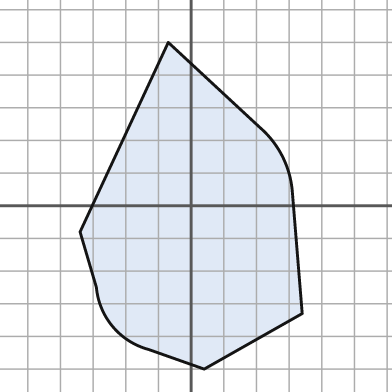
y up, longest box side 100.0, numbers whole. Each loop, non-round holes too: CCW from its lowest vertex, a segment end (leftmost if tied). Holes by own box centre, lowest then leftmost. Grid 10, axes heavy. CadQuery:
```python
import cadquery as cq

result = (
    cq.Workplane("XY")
    .moveTo(4.0, -50.0)
    .lineTo(34.0, -33.0)
    .lineTo(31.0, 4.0)
    .threePointArc((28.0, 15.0), (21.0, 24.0))
    .lineTo(-7.0, 50.0)
    .lineTo(-34.0, -8.0)
    .lineTo(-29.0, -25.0)
    .threePointArc((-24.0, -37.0), (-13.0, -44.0))
    .close()
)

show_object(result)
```